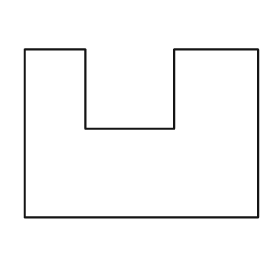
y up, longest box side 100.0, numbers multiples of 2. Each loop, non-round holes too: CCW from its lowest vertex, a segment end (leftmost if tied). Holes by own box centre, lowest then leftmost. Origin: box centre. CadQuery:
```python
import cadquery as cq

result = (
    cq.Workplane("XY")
    .moveTo(-50.0, -36.0)
    .lineTo(50.0, -36.0)
    .lineTo(50.0, 36.0)
    .lineTo(14.0, 36.0)
    .lineTo(14.0, 2.0)
    .lineTo(-24.0, 2.0)
    .lineTo(-24.0, 36.0)
    .lineTo(-50.0, 36.0)
    .close()
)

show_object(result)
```